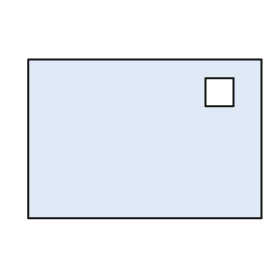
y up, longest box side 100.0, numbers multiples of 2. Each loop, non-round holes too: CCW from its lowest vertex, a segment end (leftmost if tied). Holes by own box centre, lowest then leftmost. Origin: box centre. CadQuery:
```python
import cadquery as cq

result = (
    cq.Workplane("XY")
    .moveTo(-50.0, -34.0)
    .lineTo(50.0, -34.0)
    .lineTo(50.0, 34.0)
    .lineTo(-50.0, 34.0)
    .close()
    .moveTo(26.0, 14.0)
    .lineTo(38.0, 14.0)
    .lineTo(38.0, 26.0)
    .lineTo(26.0, 26.0)
    .close()
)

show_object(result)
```